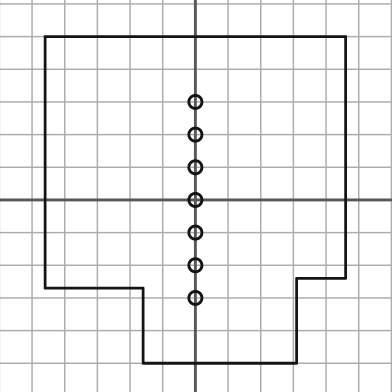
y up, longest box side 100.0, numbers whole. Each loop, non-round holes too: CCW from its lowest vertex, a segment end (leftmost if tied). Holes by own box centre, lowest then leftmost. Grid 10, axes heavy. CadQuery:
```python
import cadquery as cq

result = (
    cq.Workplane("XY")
    .moveTo(-16.0, -50.0)
    .lineTo(31.0, -50.0)
    .lineTo(31.0, -24.0)
    .lineTo(46.0, -24.0)
    .lineTo(46.0, 50.0)
    .lineTo(-46.0, 50.0)
    .lineTo(-46.0, -27.0)
    .lineTo(-16.0, -27.0)
    .close()
    .moveTo(0.0, -30.0)
    .circle(2.0)
    .moveTo(0.0, -20.0)
    .circle(2.0)
    .moveTo(0.0, -10.0)
    .circle(2.0)
    .moveTo(0.0, 0.0)
    .circle(2.0)
    .moveTo(0.0, 10.0)
    .circle(2.0)
    .moveTo(0.0, 20.0)
    .circle(2.0)
    .moveTo(0.0, 30.0)
    .circle(2.0)
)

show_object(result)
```